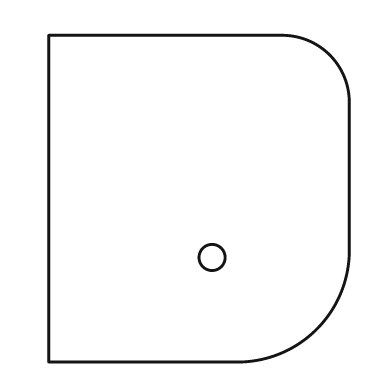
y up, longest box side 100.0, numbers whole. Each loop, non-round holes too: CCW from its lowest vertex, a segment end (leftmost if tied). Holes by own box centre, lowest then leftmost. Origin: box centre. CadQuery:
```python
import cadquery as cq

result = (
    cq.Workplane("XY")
    .moveTo(-46.0, -50.0)
    .lineTo(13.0, -50.0)
    .threePointArc((36.0, -40.0), (46.0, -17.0))
    .lineTo(46.0, 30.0)
    .threePointArc((40.0, 44.0), (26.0, 50.0))
    .lineTo(-46.0, 50.0)
    .close()
    .moveTo(4.0, -18.0)
    .circle(4.0)
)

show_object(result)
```